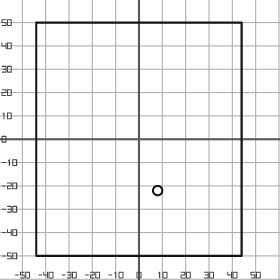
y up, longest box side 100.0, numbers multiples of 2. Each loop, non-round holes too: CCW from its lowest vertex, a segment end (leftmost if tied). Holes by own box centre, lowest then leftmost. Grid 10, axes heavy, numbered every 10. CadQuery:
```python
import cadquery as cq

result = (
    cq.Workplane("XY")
    .moveTo(-44.0, -50.0)
    .lineTo(44.0, -50.0)
    .lineTo(44.0, 50.0)
    .lineTo(-44.0, 50.0)
    .close()
    .moveTo(8.0, -22.0)
    .circle(2.0)
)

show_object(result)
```